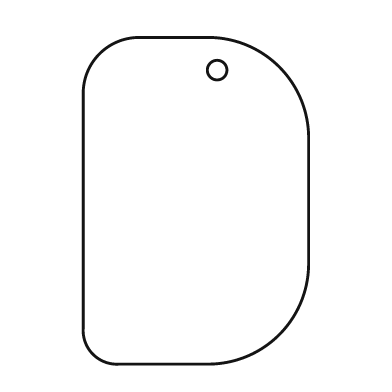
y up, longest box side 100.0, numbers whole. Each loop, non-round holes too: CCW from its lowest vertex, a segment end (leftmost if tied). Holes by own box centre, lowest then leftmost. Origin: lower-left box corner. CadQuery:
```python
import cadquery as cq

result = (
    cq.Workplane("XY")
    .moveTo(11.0, 0.0)
    .lineTo(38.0, 0.0)
    .threePointArc((60.0, 9.0), (69.0, 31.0))
    .lineTo(69.0, 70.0)
    .threePointArc((60.0, 91.0), (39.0, 100.0))
    .lineTo(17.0, 100.0)
    .threePointArc((5.0, 95.0), (0.0, 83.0))
    .lineTo(0.0, 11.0)
    .threePointArc((3.0, 3.0), (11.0, 0.0))
    .close()
    .moveTo(41.0, 90.0)
    .circle(3.0)
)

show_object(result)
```